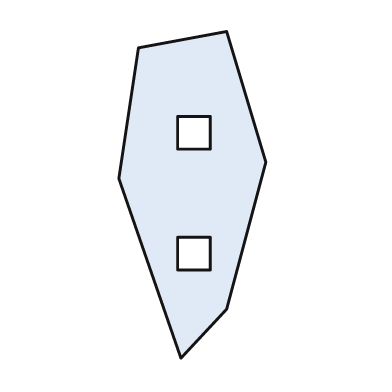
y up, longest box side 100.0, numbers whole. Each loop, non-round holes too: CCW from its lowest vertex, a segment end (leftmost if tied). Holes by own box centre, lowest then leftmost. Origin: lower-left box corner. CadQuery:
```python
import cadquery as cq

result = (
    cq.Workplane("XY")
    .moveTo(19.0, 0.0)
    .lineTo(33.0, 15.0)
    .lineTo(45.0, 60.0)
    .lineTo(33.0, 100.0)
    .lineTo(6.0, 95.0)
    .lineTo(0.0, 55.0)
    .close()
    .moveTo(18.0, 27.0)
    .lineTo(28.0, 27.0)
    .lineTo(28.0, 37.0)
    .lineTo(18.0, 37.0)
    .close()
    .moveTo(18.0, 64.0)
    .lineTo(28.0, 64.0)
    .lineTo(28.0, 74.0)
    .lineTo(18.0, 74.0)
    .close()
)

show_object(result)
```